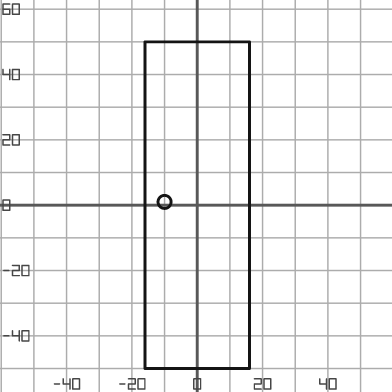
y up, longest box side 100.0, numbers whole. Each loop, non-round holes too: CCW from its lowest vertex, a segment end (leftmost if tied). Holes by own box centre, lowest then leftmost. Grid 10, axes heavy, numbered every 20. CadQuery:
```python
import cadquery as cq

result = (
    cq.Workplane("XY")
    .moveTo(-16.0, -50.0)
    .lineTo(16.0, -50.0)
    .lineTo(16.0, 50.0)
    .lineTo(-16.0, 50.0)
    .close()
    .moveTo(-10.0, 1.0)
    .circle(2.0)
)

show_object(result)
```